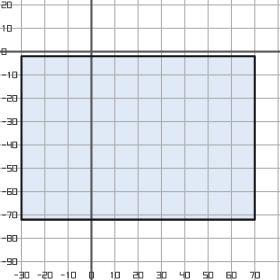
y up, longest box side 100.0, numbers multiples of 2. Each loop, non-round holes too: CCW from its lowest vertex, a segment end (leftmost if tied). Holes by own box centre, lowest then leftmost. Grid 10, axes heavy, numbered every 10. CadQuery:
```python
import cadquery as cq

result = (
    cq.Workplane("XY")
    .moveTo(-30.0, -72.0)
    .lineTo(70.0, -72.0)
    .lineTo(70.0, -2.0)
    .lineTo(-30.0, -2.0)
    .close()
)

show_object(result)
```